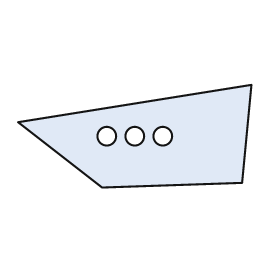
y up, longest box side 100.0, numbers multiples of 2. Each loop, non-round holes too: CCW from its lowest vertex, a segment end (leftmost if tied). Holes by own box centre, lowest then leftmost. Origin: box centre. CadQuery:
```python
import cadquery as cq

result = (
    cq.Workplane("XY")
    .moveTo(-14.0, -22.0)
    .lineTo(46.0, -20.0)
    .lineTo(50.0, 22.0)
    .lineTo(-50.0, 6.0)
    .close()
    .moveTo(-12.0, 0.0)
    .circle(4.0)
    .moveTo(0.0, 0.0)
    .circle(4.0)
    .moveTo(12.0, 0.0)
    .circle(4.0)
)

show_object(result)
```